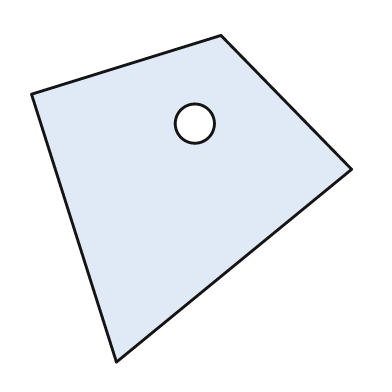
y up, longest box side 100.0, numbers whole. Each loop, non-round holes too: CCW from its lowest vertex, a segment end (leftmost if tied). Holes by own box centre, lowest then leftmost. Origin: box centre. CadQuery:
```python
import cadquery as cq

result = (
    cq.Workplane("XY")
    .moveTo(-23.0, -50.0)
    .lineTo(49.0, 9.0)
    .lineTo(9.0, 50.0)
    .lineTo(-49.0, 32.0)
    .close()
    .moveTo(1.0, 23.0)
    .circle(6.0)
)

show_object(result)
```